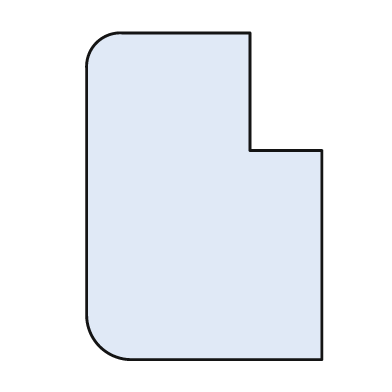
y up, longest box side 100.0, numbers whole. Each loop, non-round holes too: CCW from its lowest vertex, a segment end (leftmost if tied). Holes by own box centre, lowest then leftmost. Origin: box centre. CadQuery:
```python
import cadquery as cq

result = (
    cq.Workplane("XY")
    .moveTo(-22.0, -50.0)
    .lineTo(36.0, -50.0)
    .lineTo(36.0, 14.0)
    .lineTo(14.0, 14.0)
    .lineTo(14.0, 50.0)
    .lineTo(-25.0, 50.0)
    .threePointArc((-33.0, 47.0), (-36.0, 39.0))
    .lineTo(-36.0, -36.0)
    .threePointArc((-32.0, -46.0), (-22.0, -50.0))
    .close()
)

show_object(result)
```